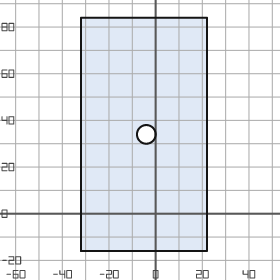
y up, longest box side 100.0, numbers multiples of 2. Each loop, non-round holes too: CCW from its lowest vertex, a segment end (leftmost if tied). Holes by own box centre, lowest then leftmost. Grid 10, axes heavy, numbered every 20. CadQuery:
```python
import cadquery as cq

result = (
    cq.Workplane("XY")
    .moveTo(-32.0, -16.0)
    .lineTo(22.0, -16.0)
    .lineTo(22.0, 84.0)
    .lineTo(-32.0, 84.0)
    .close()
    .moveTo(-4.0, 34.0)
    .circle(4.0)
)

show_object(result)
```